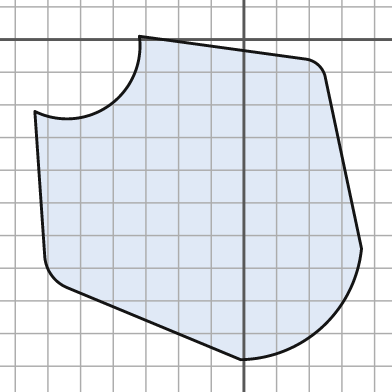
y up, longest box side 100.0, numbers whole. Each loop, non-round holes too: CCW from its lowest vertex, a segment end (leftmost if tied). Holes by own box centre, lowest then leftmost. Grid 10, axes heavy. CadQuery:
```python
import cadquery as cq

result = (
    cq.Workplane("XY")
    .moveTo(-1.0, -98.0)
    .threePointArc((24.0, -88.0), (36.0, -64.0))
    .lineTo(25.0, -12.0)
    .threePointArc((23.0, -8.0), (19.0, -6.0))
    .lineTo(-32.0, 1.0)
    .threePointArc((-41.0, -20.0), (-64.0, -22.0))
    .lineTo(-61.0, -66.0)
    .threePointArc((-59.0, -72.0), (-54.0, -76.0))
    .close()
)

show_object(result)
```